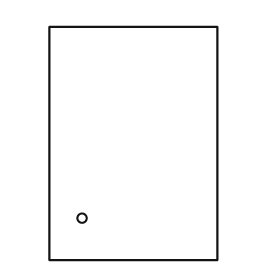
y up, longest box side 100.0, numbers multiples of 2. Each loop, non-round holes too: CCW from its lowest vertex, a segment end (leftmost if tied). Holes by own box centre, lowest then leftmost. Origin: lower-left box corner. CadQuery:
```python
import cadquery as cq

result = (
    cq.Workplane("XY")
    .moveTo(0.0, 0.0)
    .lineTo(72.0, 0.0)
    .lineTo(72.0, 100.0)
    .lineTo(0.0, 100.0)
    .close()
    .moveTo(14.0, 18.0)
    .circle(2.0)
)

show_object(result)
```